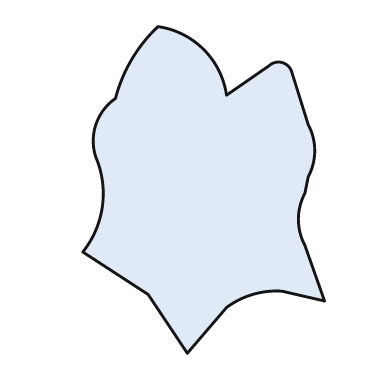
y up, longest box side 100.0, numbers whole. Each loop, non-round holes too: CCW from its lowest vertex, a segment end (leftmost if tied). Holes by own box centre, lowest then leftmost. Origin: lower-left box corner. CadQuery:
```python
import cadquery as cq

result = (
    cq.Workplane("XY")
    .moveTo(32.0, 0.0)
    .lineTo(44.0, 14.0)
    .threePointArc((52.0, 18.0), (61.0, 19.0))
    .lineTo(74.0, 16.0)
    .lineTo(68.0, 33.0)
    .threePointArc((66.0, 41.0), (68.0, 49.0))
    .lineTo(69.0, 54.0)
    .threePointArc((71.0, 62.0), (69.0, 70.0))
    .lineTo(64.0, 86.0)
    .threePointArc((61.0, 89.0), (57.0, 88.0))
    .lineTo(44.0, 79.0)
    .threePointArc((37.0, 93.0), (23.0, 100.0))
    .threePointArc((15.0, 90.0), (10.0, 78.0))
    .threePointArc((4.0, 70.0), (4.0, 60.0))
    .threePointArc((6.0, 45.0), (0.0, 31.0))
    .lineTo(20.0, 18.0)
    .close()
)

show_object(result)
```